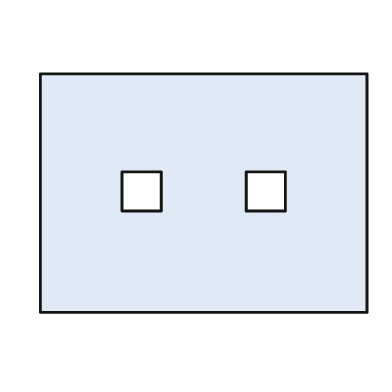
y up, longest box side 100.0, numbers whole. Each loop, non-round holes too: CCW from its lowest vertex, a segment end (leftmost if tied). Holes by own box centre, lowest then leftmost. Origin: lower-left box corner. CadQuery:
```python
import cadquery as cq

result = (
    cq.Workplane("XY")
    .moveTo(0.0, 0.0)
    .lineTo(100.0, 0.0)
    .lineTo(100.0, 73.0)
    .lineTo(0.0, 73.0)
    .close()
    .moveTo(25.0, 31.0)
    .lineTo(37.0, 31.0)
    .lineTo(37.0, 43.0)
    .lineTo(25.0, 43.0)
    .close()
    .moveTo(63.0, 31.0)
    .lineTo(75.0, 31.0)
    .lineTo(75.0, 43.0)
    .lineTo(63.0, 43.0)
    .close()
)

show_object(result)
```